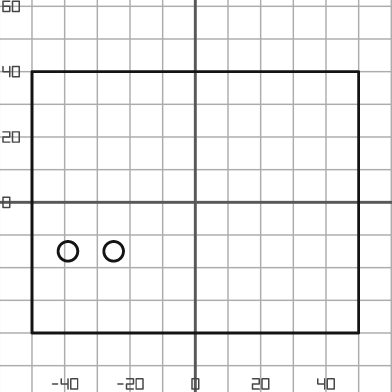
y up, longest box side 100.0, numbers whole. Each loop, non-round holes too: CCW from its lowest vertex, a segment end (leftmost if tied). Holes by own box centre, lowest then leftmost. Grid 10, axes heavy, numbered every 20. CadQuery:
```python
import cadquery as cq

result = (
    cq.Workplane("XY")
    .moveTo(-50.0, -40.0)
    .lineTo(50.0, -40.0)
    .lineTo(50.0, 40.0)
    .lineTo(-50.0, 40.0)
    .close()
    .moveTo(-39.0, -15.0)
    .circle(3.0)
    .moveTo(-25.0, -15.0)
    .circle(3.0)
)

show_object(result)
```